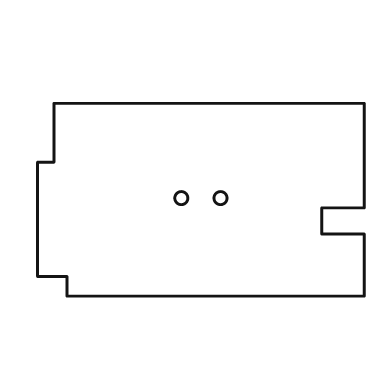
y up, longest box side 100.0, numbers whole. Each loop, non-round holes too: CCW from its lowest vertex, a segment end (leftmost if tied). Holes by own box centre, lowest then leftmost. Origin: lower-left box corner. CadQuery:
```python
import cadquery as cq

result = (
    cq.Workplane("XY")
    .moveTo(9.0, 0.0)
    .lineTo(100.0, 0.0)
    .lineTo(100.0, 19.0)
    .lineTo(87.0, 19.0)
    .lineTo(87.0, 27.0)
    .lineTo(100.0, 27.0)
    .lineTo(100.0, 59.0)
    .lineTo(5.0, 59.0)
    .lineTo(5.0, 41.0)
    .lineTo(0.0, 41.0)
    .lineTo(0.0, 6.0)
    .lineTo(9.0, 6.0)
    .close()
    .moveTo(44.0, 30.0)
    .circle(2.0)
    .moveTo(56.0, 30.0)
    .circle(2.0)
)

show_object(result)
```